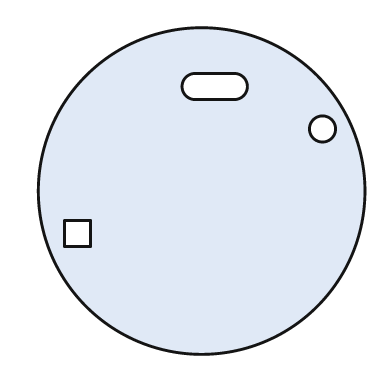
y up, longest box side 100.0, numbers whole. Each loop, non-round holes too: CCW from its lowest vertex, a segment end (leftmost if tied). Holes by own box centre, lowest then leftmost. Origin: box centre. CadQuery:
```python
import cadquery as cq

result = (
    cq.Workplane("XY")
    .moveTo(0.0, 0.0)
    .circle(50.0)
    .moveTo(-42.0, -17.0)
    .lineTo(-34.0, -17.0)
    .lineTo(-34.0, -9.0)
    .lineTo(-42.0, -9.0)
    .close()
    .moveTo(37.0, 19.0)
    .circle(4.0)
    .moveTo(-2.0, 28.0)
    .lineTo(10.0, 28.0)
    .threePointArc((14.0, 32.0), (10.0, 36.0))
    .lineTo(-2.0, 36.0)
    .threePointArc((-6.0, 32.0), (-2.0, 28.0))
    .close()
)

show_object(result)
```